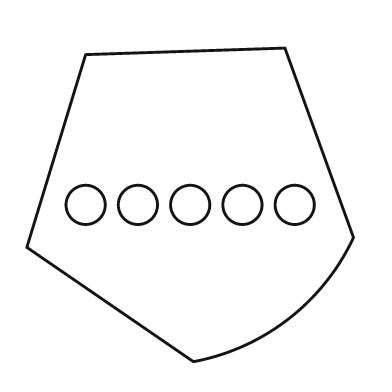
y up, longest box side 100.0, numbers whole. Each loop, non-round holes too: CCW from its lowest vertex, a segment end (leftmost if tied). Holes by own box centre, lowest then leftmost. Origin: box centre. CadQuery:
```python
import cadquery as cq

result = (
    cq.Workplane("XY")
    .moveTo(1.0, -48.0)
    .threePointArc((30.0, -35.0), (50.0, -10.0))
    .lineTo(29.0, 48.0)
    .lineTo(-32.0, 46.0)
    .lineTo(-50.0, -13.0)
    .close()
    .moveTo(-32.0, 0.0)
    .circle(6.0)
    .moveTo(-16.0, 0.0)
    .circle(6.0)
    .moveTo(0.0, 0.0)
    .circle(6.0)
    .moveTo(16.0, 0.0)
    .circle(6.0)
    .moveTo(32.0, 0.0)
    .circle(6.0)
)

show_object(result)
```